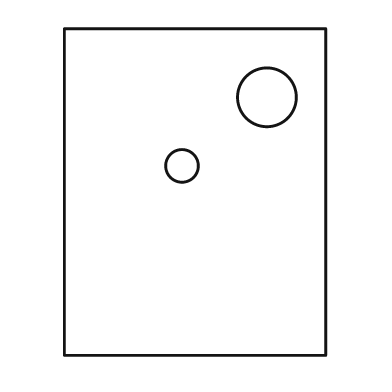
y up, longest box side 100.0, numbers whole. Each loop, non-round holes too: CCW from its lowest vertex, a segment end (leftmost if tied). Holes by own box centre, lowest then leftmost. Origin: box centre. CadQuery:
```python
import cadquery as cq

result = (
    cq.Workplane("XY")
    .moveTo(-40.0, -50.0)
    .lineTo(40.0, -50.0)
    .lineTo(40.0, 50.0)
    .lineTo(-40.0, 50.0)
    .close()
    .moveTo(-4.0, 8.0)
    .circle(5.0)
    .moveTo(22.0, 29.0)
    .circle(9.0)
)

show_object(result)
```